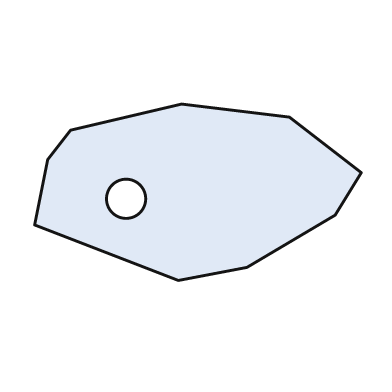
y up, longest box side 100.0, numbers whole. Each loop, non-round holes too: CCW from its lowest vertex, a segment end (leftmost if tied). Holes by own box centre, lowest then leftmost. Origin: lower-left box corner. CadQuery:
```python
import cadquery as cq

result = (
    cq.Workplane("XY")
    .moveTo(44.0, 0.0)
    .lineTo(65.0, 4.0)
    .lineTo(92.0, 20.0)
    .lineTo(100.0, 33.0)
    .lineTo(78.0, 50.0)
    .lineTo(45.0, 54.0)
    .lineTo(11.0, 46.0)
    .lineTo(4.0, 37.0)
    .lineTo(0.0, 17.0)
    .close()
    .moveTo(28.0, 25.0)
    .circle(6.0)
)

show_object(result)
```